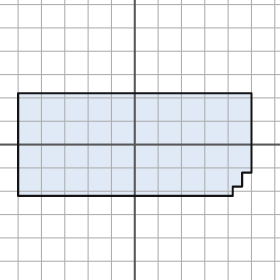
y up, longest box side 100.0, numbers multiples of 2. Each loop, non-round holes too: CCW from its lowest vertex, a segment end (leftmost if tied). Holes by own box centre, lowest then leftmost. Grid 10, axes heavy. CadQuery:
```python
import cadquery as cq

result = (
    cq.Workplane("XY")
    .moveTo(-50.0, -22.0)
    .lineTo(42.0, -22.0)
    .lineTo(42.0, -18.0)
    .lineTo(46.0, -18.0)
    .lineTo(46.0, -12.0)
    .lineTo(50.0, -12.0)
    .lineTo(50.0, 22.0)
    .lineTo(-50.0, 22.0)
    .close()
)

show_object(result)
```